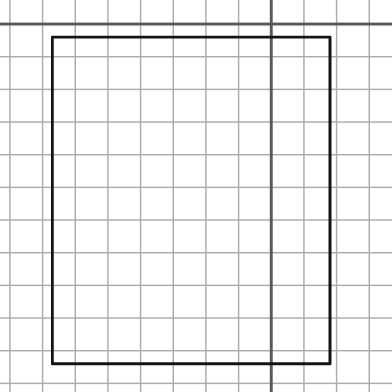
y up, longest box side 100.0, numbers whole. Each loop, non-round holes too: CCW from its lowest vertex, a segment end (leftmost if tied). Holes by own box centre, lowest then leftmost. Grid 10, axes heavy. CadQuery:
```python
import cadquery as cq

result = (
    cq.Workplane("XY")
    .moveTo(-67.0, -104.0)
    .lineTo(18.0, -104.0)
    .lineTo(18.0, -4.0)
    .lineTo(-67.0, -4.0)
    .close()
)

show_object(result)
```